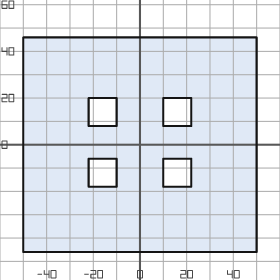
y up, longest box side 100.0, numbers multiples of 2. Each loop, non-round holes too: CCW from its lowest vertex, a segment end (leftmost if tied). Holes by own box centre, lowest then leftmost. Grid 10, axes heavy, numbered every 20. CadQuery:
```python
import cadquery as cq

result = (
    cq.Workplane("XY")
    .moveTo(-50.0, -46.0)
    .lineTo(50.0, -46.0)
    .lineTo(50.0, 46.0)
    .lineTo(-50.0, 46.0)
    .close()
    .moveTo(-22.0, -18.0)
    .lineTo(-10.0, -18.0)
    .lineTo(-10.0, -6.0)
    .lineTo(-22.0, -6.0)
    .close()
    .moveTo(10.0, -18.0)
    .lineTo(22.0, -18.0)
    .lineTo(22.0, -6.0)
    .lineTo(10.0, -6.0)
    .close()
    .moveTo(-22.0, 8.0)
    .lineTo(-10.0, 8.0)
    .lineTo(-10.0, 20.0)
    .lineTo(-22.0, 20.0)
    .close()
    .moveTo(10.0, 8.0)
    .lineTo(22.0, 8.0)
    .lineTo(22.0, 20.0)
    .lineTo(10.0, 20.0)
    .close()
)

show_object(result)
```